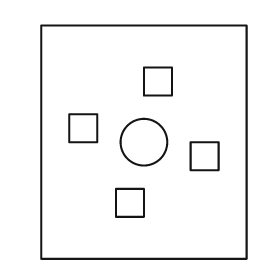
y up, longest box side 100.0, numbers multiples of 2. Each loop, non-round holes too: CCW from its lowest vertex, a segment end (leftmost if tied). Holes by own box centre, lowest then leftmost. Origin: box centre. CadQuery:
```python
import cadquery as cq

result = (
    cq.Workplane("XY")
    .moveTo(-44.0, -50.0)
    .lineTo(44.0, -50.0)
    .lineTo(44.0, 50.0)
    .lineTo(-44.0, 50.0)
    .close()
    .moveTo(-12.0, -32.0)
    .lineTo(0.0, -32.0)
    .lineTo(0.0, -20.0)
    .lineTo(-12.0, -20.0)
    .close()
    .moveTo(20.0, -12.0)
    .lineTo(32.0, -12.0)
    .lineTo(32.0, 0.0)
    .lineTo(20.0, 0.0)
    .close()
    .moveTo(0.0, 0.0)
    .circle(10.0)
    .moveTo(-32.0, 0.0)
    .lineTo(-20.0, 0.0)
    .lineTo(-20.0, 12.0)
    .lineTo(-32.0, 12.0)
    .close()
    .moveTo(0.0, 20.0)
    .lineTo(12.0, 20.0)
    .lineTo(12.0, 32.0)
    .lineTo(0.0, 32.0)
    .close()
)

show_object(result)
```